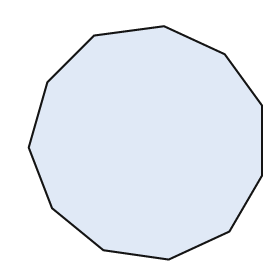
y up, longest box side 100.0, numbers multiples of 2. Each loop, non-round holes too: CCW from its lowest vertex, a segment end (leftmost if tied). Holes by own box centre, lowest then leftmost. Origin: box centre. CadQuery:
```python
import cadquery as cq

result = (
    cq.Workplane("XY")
    .moveTo(10.0, -50.0)
    .lineTo(36.0, -38.0)
    .lineTo(50.0, -14.0)
    .lineTo(50.0, 16.0)
    .lineTo(34.0, 38.0)
    .lineTo(8.0, 50.0)
    .lineTo(-22.0, 46.0)
    .lineTo(-42.0, 26.0)
    .lineTo(-50.0, -2.0)
    .lineTo(-40.0, -28.0)
    .lineTo(-18.0, -46.0)
    .close()
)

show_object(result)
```